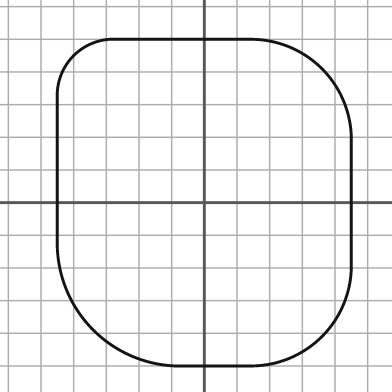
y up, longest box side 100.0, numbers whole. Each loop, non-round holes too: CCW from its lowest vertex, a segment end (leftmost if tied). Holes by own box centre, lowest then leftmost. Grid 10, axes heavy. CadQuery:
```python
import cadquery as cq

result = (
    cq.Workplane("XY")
    .moveTo(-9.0, -50.0)
    .lineTo(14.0, -50.0)
    .threePointArc((36.0, -41.0), (45.0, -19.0))
    .lineTo(45.0, 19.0)
    .threePointArc((36.0, 41.0), (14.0, 50.0))
    .lineTo(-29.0, 50.0)
    .threePointArc((-40.0, 45.0), (-45.0, 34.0))
    .lineTo(-45.0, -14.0)
    .threePointArc((-34.0, -39.0), (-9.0, -50.0))
    .close()
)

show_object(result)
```